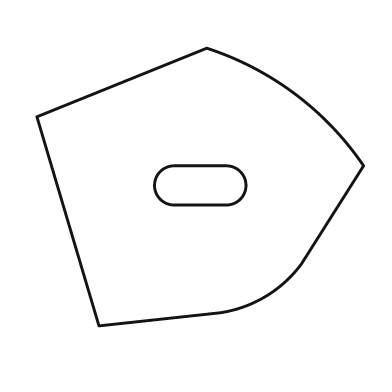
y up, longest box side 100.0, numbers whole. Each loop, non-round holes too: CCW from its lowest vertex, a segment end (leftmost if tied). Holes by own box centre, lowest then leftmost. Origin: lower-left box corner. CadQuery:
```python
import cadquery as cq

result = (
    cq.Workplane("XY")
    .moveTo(19.0, 0.0)
    .lineTo(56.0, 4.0)
    .threePointArc((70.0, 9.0), (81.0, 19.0))
    .lineTo(100.0, 49.0)
    .threePointArc((79.0, 71.0), (52.0, 85.0))
    .lineTo(0.0, 64.0)
    .close()
    .moveTo(42.0, 37.0)
    .lineTo(58.0, 37.0)
    .threePointArc((64.0, 43.0), (58.0, 49.0))
    .lineTo(42.0, 49.0)
    .threePointArc((36.0, 43.0), (42.0, 37.0))
    .close()
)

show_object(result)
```